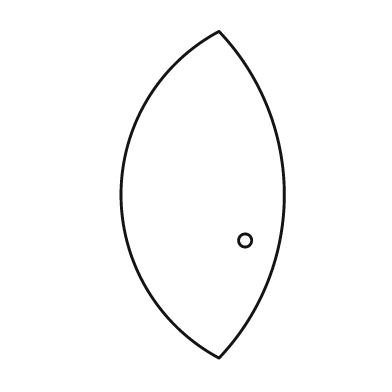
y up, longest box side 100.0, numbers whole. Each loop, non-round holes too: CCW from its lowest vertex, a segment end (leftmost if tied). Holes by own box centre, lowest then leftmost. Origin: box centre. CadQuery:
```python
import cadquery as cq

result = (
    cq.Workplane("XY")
    .moveTo(5.0, -50.0)
    .threePointArc((25.0, 0.0), (5.0, 50.0))
    .threePointArc((-25.0, 0.0), (5.0, -50.0))
    .close()
    .moveTo(13.0, -14.0)
    .circle(2.0)
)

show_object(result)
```